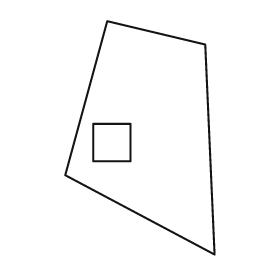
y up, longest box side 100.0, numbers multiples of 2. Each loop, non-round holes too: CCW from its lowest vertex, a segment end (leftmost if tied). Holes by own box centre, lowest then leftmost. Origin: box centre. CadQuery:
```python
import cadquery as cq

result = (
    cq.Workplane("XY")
    .moveTo(32.0, -50.0)
    .lineTo(28.0, 40.0)
    .lineTo(-14.0, 50.0)
    .lineTo(-32.0, -16.0)
    .close()
    .moveTo(-20.0, -10.0)
    .lineTo(-4.0, -10.0)
    .lineTo(-4.0, 6.0)
    .lineTo(-20.0, 6.0)
    .close()
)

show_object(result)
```